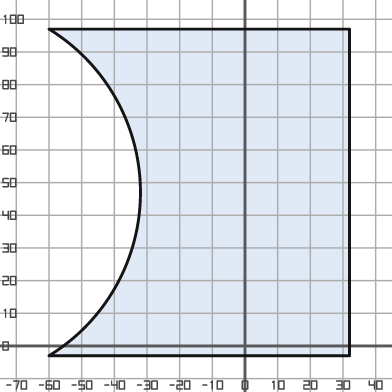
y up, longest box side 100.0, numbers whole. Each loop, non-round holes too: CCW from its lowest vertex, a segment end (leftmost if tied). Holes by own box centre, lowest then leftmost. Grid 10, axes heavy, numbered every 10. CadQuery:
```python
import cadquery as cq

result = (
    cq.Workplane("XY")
    .moveTo(-60.0, -3.0)
    .lineTo(32.0, -3.0)
    .lineTo(32.0, 97.0)
    .lineTo(-60.0, 97.0)
    .threePointArc((-32.0, 47.0), (-60.0, -3.0))
    .close()
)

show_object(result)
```